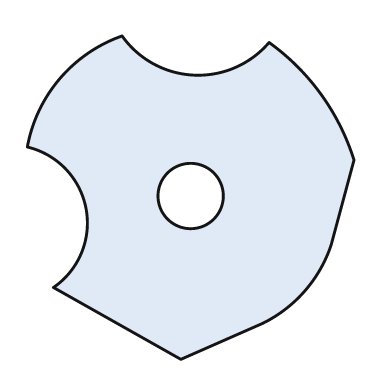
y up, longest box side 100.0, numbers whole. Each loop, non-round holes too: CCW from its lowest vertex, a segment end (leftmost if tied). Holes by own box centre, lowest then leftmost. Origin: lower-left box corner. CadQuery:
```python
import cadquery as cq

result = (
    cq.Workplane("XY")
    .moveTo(47.0, 0.0)
    .lineTo(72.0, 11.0)
    .threePointArc((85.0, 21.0), (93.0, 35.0))
    .lineTo(100.0, 61.0)
    .threePointArc((90.0, 81.0), (74.0, 97.0))
    .threePointArc((51.0, 87.0), (29.0, 99.0))
    .threePointArc((10.0, 86.0), (0.0, 65.0))
    .threePointArc((18.0, 46.0), (8.0, 22.0))
    .close()
    .moveTo(50.0, 50.0)
    .circle(10.0)
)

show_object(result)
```